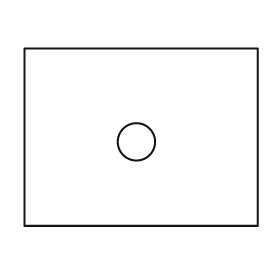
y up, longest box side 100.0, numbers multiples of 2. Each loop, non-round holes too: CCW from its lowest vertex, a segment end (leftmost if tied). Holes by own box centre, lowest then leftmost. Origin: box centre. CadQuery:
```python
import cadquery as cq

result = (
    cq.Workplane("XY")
    .moveTo(-50.0, -38.0)
    .lineTo(50.0, -38.0)
    .lineTo(50.0, 38.0)
    .lineTo(-50.0, 38.0)
    .close()
    .moveTo(-2.0, -2.0)
    .circle(8.0)
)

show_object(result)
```